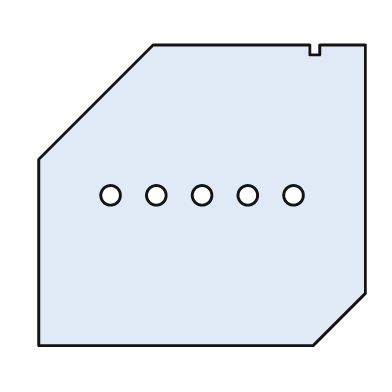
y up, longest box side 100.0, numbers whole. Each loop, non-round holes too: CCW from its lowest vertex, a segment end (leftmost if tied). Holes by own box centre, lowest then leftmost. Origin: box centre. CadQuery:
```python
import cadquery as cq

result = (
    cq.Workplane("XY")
    .moveTo(-50.0, -46.0)
    .lineTo(34.0, -46.0)
    .lineTo(50.0, -30.0)
    .lineTo(50.0, 46.0)
    .lineTo(36.0, 46.0)
    .lineTo(36.0, 43.0)
    .lineTo(33.0, 43.0)
    .lineTo(33.0, 46.0)
    .lineTo(-15.0, 46.0)
    .lineTo(-50.0, 11.0)
    .close()
    .moveTo(-28.0, 0.0)
    .circle(3.0)
    .moveTo(-14.0, 0.0)
    .circle(3.0)
    .moveTo(0.0, 0.0)
    .circle(3.0)
    .moveTo(14.0, 0.0)
    .circle(3.0)
    .moveTo(28.0, 0.0)
    .circle(3.0)
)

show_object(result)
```